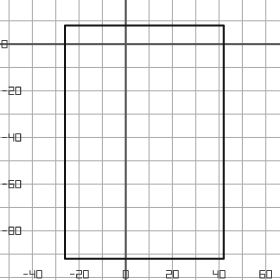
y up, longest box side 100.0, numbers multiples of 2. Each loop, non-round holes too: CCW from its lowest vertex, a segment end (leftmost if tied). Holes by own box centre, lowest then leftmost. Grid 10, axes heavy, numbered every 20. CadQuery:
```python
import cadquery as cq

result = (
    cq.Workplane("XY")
    .moveTo(-26.0, -92.0)
    .lineTo(42.0, -92.0)
    .lineTo(42.0, 8.0)
    .lineTo(-26.0, 8.0)
    .close()
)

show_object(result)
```